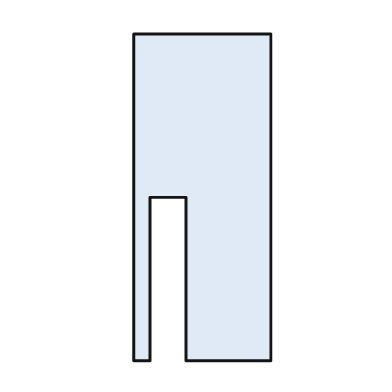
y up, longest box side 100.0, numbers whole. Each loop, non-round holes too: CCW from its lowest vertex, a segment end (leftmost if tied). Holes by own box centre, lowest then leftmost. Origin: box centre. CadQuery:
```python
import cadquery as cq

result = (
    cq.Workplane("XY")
    .moveTo(-21.0, -50.0)
    .lineTo(-16.0, -50.0)
    .lineTo(-16.0, 0.0)
    .lineTo(-5.0, 0.0)
    .lineTo(-5.0, -50.0)
    .lineTo(21.0, -50.0)
    .lineTo(21.0, 50.0)
    .lineTo(-21.0, 50.0)
    .close()
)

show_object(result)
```